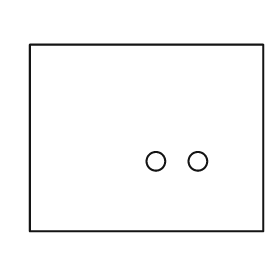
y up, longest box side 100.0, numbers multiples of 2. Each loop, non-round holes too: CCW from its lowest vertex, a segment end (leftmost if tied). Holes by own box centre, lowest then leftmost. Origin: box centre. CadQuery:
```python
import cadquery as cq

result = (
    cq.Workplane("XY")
    .moveTo(-50.0, -40.0)
    .lineTo(50.0, -40.0)
    .lineTo(50.0, 40.0)
    .lineTo(-50.0, 40.0)
    .close()
    .moveTo(4.0, -10.0)
    .circle(4.0)
    .moveTo(22.0, -10.0)
    .circle(4.0)
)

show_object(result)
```